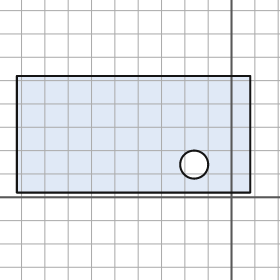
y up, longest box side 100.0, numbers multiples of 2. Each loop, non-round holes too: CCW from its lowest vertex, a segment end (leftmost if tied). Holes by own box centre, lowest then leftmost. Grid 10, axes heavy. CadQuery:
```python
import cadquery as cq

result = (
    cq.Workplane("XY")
    .moveTo(-92.0, 2.0)
    .lineTo(8.0, 2.0)
    .lineTo(8.0, 52.0)
    .lineTo(-92.0, 52.0)
    .close()
    .moveTo(-16.0, 14.0)
    .circle(6.0)
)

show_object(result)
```